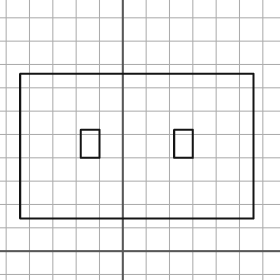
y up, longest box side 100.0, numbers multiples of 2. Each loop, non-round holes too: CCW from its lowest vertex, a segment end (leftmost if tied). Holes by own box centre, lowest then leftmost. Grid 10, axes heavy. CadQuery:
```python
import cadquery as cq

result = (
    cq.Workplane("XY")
    .moveTo(-44.0, 14.0)
    .lineTo(56.0, 14.0)
    .lineTo(56.0, 76.0)
    .lineTo(-44.0, 76.0)
    .close()
    .moveTo(-18.0, 40.0)
    .lineTo(-10.0, 40.0)
    .lineTo(-10.0, 52.0)
    .lineTo(-18.0, 52.0)
    .close()
    .moveTo(22.0, 40.0)
    .lineTo(30.0, 40.0)
    .lineTo(30.0, 52.0)
    .lineTo(22.0, 52.0)
    .close()
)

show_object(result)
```